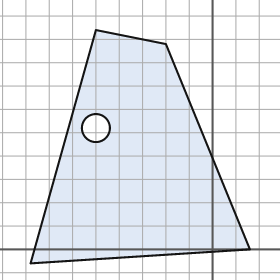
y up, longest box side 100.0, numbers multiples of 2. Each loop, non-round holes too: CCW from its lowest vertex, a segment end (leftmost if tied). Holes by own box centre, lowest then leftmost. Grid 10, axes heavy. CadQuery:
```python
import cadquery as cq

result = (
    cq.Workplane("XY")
    .moveTo(-78.0, -6.0)
    .lineTo(16.0, 0.0)
    .lineTo(-20.0, 88.0)
    .lineTo(-50.0, 94.0)
    .close()
    .moveTo(-50.0, 52.0)
    .circle(6.0)
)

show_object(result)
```